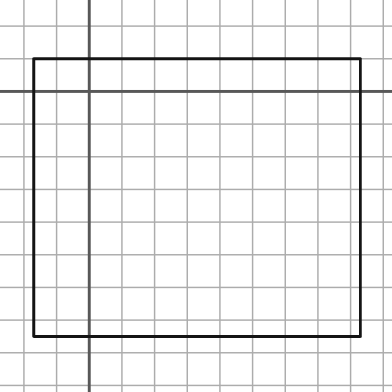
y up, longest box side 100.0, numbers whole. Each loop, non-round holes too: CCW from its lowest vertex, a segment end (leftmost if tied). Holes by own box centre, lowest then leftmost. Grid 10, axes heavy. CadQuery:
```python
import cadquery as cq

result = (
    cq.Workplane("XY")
    .moveTo(-17.0, -75.0)
    .lineTo(83.0, -75.0)
    .lineTo(83.0, 10.0)
    .lineTo(-17.0, 10.0)
    .close()
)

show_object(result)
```